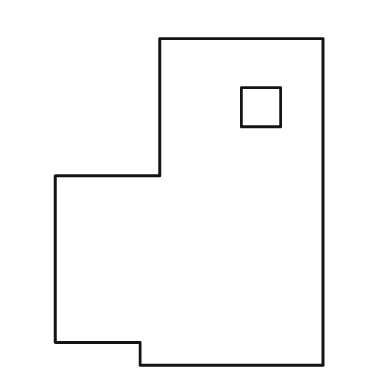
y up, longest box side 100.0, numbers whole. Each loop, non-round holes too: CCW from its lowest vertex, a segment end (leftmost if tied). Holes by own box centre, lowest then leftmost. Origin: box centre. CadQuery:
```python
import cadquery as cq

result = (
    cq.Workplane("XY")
    .moveTo(-15.0, -50.0)
    .lineTo(41.0, -50.0)
    .lineTo(41.0, 50.0)
    .lineTo(-9.0, 50.0)
    .lineTo(-9.0, 8.0)
    .lineTo(-41.0, 8.0)
    .lineTo(-41.0, -43.0)
    .lineTo(-15.0, -43.0)
    .close()
    .moveTo(16.0, 23.0)
    .lineTo(28.0, 23.0)
    .lineTo(28.0, 35.0)
    .lineTo(16.0, 35.0)
    .close()
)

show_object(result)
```